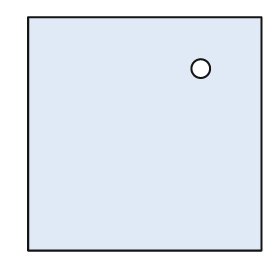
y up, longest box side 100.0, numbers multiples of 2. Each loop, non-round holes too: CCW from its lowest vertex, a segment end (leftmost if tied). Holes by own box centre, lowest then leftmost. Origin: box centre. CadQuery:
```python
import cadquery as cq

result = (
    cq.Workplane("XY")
    .moveTo(-50.0, -50.0)
    .lineTo(50.0, -50.0)
    .lineTo(50.0, 50.0)
    .lineTo(-50.0, 50.0)
    .close()
    .moveTo(24.0, 28.0)
    .circle(4.0)
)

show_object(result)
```